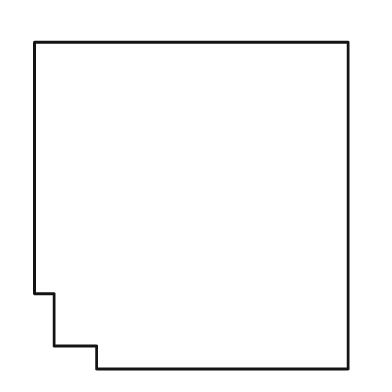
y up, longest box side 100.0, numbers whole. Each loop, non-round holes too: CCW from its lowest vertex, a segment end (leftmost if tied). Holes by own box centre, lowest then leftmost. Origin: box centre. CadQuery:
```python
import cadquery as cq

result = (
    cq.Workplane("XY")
    .moveTo(-29.0, -50.0)
    .lineTo(48.0, -50.0)
    .lineTo(48.0, 50.0)
    .lineTo(-48.0, 50.0)
    .lineTo(-48.0, -27.0)
    .lineTo(-42.0, -27.0)
    .lineTo(-42.0, -43.0)
    .lineTo(-29.0, -43.0)
    .close()
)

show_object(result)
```